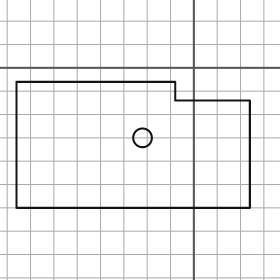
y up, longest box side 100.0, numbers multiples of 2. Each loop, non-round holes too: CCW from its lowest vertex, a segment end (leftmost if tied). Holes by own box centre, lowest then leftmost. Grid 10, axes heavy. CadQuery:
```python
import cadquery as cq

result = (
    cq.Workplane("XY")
    .moveTo(-76.0, -60.0)
    .lineTo(24.0, -60.0)
    .lineTo(24.0, -14.0)
    .lineTo(-8.0, -14.0)
    .lineTo(-8.0, -6.0)
    .lineTo(-76.0, -6.0)
    .close()
    .moveTo(-22.0, -30.0)
    .circle(4.0)
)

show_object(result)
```